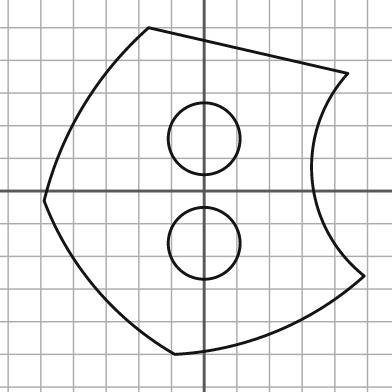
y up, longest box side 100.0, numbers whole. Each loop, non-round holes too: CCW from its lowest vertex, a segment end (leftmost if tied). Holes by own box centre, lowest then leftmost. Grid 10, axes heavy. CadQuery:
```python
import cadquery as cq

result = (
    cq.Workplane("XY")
    .moveTo(-9.0, -50.0)
    .threePointArc((22.0, -43.0), (49.0, -26.0))
    .threePointArc((33.0, 4.0), (44.0, 36.0))
    .lineTo(-17.0, 50.0)
    .threePointArc((-37.0, 26.0), (-49.0, -3.0))
    .threePointArc((-33.0, -30.0), (-9.0, -50.0))
    .close()
    .moveTo(0.0, -16.0)
    .circle(11.0)
    .moveTo(0.0, 16.0)
    .circle(11.0)
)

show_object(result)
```